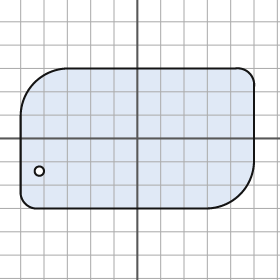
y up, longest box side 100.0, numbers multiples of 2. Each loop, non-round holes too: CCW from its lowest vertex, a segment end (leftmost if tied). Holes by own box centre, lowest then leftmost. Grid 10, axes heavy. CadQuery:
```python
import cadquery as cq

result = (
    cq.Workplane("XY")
    .moveTo(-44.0, -30.0)
    .lineTo(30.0, -30.0)
    .threePointArc((44.0, -24.0), (50.0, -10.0))
    .lineTo(50.0, 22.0)
    .threePointArc((48.0, 28.0), (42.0, 30.0))
    .lineTo(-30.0, 30.0)
    .threePointArc((-44.0, 24.0), (-50.0, 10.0))
    .lineTo(-50.0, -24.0)
    .threePointArc((-48.0, -28.0), (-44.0, -30.0))
    .close()
    .moveTo(-42.0, -14.0)
    .circle(2.0)
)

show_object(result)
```